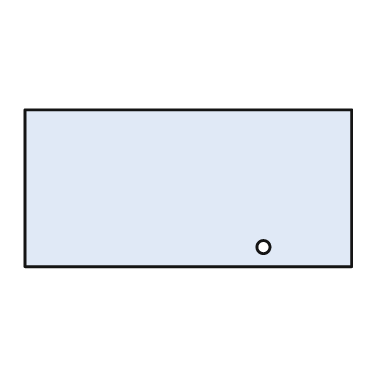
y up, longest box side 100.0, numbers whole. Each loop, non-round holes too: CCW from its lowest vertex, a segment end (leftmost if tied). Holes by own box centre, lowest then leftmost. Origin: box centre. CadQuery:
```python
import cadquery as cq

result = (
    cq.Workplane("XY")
    .moveTo(-50.0, -24.0)
    .lineTo(50.0, -24.0)
    .lineTo(50.0, 24.0)
    .lineTo(-50.0, 24.0)
    .close()
    .moveTo(23.0, -18.0)
    .circle(2.0)
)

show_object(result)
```